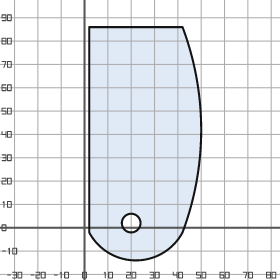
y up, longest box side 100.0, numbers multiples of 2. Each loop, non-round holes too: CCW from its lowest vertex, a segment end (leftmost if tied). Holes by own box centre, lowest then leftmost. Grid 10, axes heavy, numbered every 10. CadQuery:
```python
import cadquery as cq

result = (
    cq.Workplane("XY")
    .moveTo(2.0, -2.0)
    .threePointArc((22.0, -14.0), (42.0, -2.0))
    .threePointArc((50.0, 42.0), (42.0, 86.0))
    .lineTo(2.0, 86.0)
    .close()
    .moveTo(20.0, 2.0)
    .circle(4.0)
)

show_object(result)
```